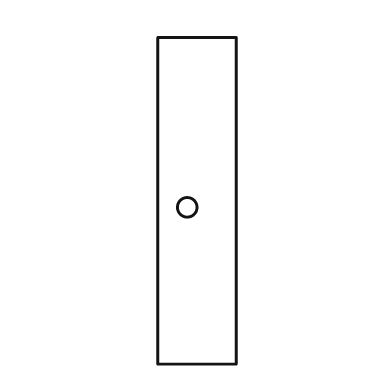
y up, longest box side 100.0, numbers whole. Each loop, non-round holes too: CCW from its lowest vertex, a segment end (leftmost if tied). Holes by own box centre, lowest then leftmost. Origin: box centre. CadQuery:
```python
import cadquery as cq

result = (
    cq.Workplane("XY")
    .moveTo(-12.0, -50.0)
    .lineTo(12.0, -50.0)
    .lineTo(12.0, 50.0)
    .lineTo(-12.0, 50.0)
    .close()
    .moveTo(-3.0, -2.0)
    .circle(3.0)
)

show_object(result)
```